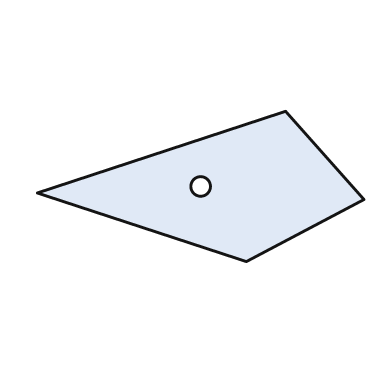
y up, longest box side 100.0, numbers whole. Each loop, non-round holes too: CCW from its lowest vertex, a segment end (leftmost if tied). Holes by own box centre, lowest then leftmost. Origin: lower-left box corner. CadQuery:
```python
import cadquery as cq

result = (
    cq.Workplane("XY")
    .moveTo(64.0, 0.0)
    .lineTo(100.0, 19.0)
    .lineTo(76.0, 46.0)
    .lineTo(0.0, 21.0)
    .close()
    .moveTo(50.0, 23.0)
    .circle(3.0)
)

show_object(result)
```